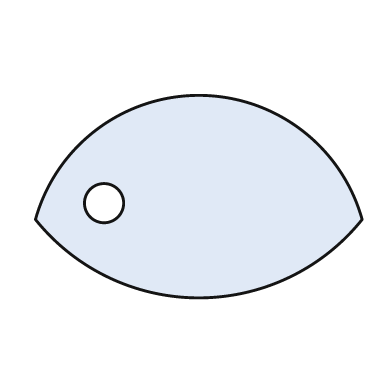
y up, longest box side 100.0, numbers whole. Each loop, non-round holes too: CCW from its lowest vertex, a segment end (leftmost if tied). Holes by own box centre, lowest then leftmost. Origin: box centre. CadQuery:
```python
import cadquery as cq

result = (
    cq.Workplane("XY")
    .moveTo(-50.0, -7.0)
    .threePointArc((0.0, -31.0), (50.0, -7.0))
    .threePointArc((0.0, 31.0), (-50.0, -7.0))
    .close()
    .moveTo(-29.0, -2.0)
    .circle(6.0)
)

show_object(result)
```